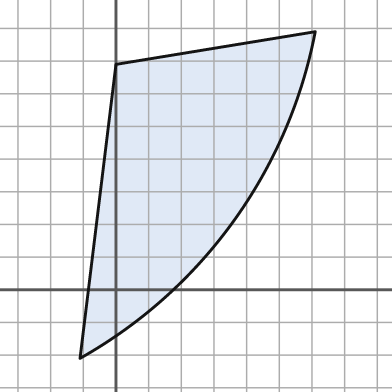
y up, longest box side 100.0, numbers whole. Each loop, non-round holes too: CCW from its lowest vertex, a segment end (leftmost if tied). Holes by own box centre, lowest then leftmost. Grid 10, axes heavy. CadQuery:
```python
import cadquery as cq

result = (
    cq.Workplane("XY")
    .moveTo(-11.0, -21.0)
    .threePointArc((36.0, 21.0), (61.0, 79.0))
    .lineTo(0.0, 69.0)
    .close()
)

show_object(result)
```